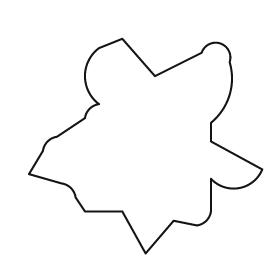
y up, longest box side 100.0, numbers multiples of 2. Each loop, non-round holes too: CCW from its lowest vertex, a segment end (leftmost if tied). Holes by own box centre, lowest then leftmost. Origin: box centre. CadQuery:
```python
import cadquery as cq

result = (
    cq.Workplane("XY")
    .moveTo(0.0, -46.0)
    .lineTo(12.0, -32.0)
    .lineTo(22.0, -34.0)
    .threePointArc((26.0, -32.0), (28.0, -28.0))
    .lineTo(28.0, -14.0)
    .threePointArc((40.0, -18.0), (50.0, -10.0))
    .lineTo(28.0, 2.0)
    .lineTo(28.0, 10.0)
    .threePointArc((36.0, 22.0), (36.0, 36.0))
    .threePointArc((32.0, 44.0), (24.0, 40.0))
    .lineTo(4.0, 30.0)
    .lineTo(-10.0, 46.0)
    .lineTo(-20.0, 42.0)
    .threePointArc((-26.0, 30.0), (-20.0, 18.0))
    .threePointArc((-24.0, 16.0), (-26.0, 12.0))
    .lineTo(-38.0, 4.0)
    .threePointArc((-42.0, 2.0), (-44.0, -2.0))
    .lineTo(-50.0, -12.0)
    .lineTo(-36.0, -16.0)
    .threePointArc((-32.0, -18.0), (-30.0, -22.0))
    .lineTo(-26.0, -28.0)
    .lineTo(-10.0, -28.0)
    .close()
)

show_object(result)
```